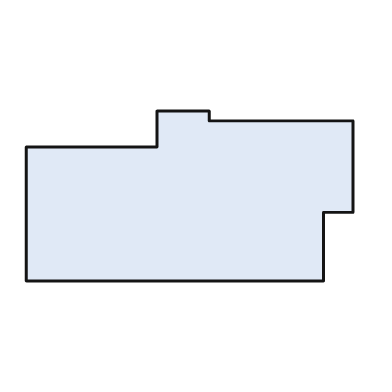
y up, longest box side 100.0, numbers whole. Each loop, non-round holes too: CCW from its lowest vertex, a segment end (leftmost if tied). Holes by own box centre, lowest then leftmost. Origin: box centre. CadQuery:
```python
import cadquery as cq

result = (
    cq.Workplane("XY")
    .moveTo(-50.0, -26.0)
    .lineTo(41.0, -26.0)
    .lineTo(41.0, -5.0)
    .lineTo(50.0, -5.0)
    .lineTo(50.0, 23.0)
    .lineTo(6.0, 23.0)
    .lineTo(6.0, 26.0)
    .lineTo(-10.0, 26.0)
    .lineTo(-10.0, 15.0)
    .lineTo(-50.0, 15.0)
    .close()
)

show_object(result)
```